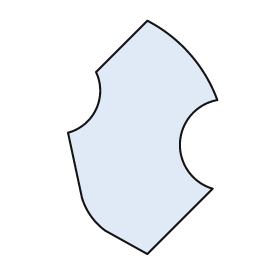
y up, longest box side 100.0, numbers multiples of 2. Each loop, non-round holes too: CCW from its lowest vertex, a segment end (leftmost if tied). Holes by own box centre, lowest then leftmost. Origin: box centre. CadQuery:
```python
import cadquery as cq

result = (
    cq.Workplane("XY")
    .moveTo(2.0, -50.0)
    .lineTo(30.0, -22.0)
    .threePointArc((16.0, -2.0), (32.0, 16.0))
    .threePointArc((20.0, 36.0), (2.0, 50.0))
    .lineTo(-20.0, 28.0)
    .threePointArc((-20.0, 12.0), (-32.0, 2.0))
    .lineTo(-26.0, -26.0)
    .threePointArc((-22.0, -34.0), (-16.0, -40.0))
    .close()
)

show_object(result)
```